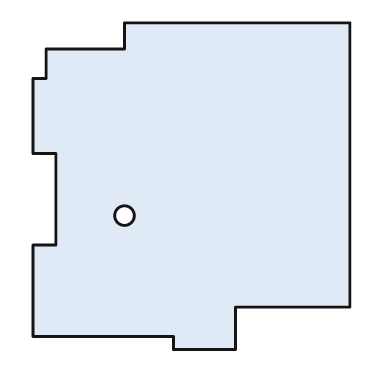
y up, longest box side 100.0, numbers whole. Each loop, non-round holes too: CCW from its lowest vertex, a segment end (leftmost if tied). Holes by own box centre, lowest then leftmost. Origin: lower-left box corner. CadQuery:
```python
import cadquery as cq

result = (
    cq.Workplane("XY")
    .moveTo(43.0, 0.0)
    .lineTo(62.0, 0.0)
    .lineTo(62.0, 13.0)
    .lineTo(97.0, 13.0)
    .lineTo(97.0, 100.0)
    .lineTo(28.0, 100.0)
    .lineTo(28.0, 92.0)
    .lineTo(4.0, 92.0)
    .lineTo(4.0, 83.0)
    .lineTo(0.0, 83.0)
    .lineTo(0.0, 60.0)
    .lineTo(7.0, 60.0)
    .lineTo(7.0, 32.0)
    .lineTo(0.0, 32.0)
    .lineTo(0.0, 4.0)
    .lineTo(43.0, 4.0)
    .close()
    .moveTo(28.0, 41.0)
    .circle(3.0)
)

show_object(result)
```